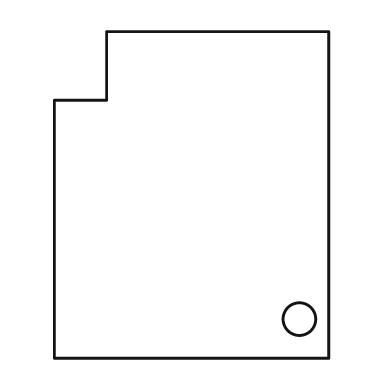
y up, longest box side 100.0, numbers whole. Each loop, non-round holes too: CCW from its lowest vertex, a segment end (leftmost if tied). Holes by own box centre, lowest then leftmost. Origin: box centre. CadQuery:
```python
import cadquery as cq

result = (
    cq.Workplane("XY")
    .moveTo(-42.0, -50.0)
    .lineTo(42.0, -50.0)
    .lineTo(42.0, 50.0)
    .lineTo(-26.0, 50.0)
    .lineTo(-26.0, 29.0)
    .lineTo(-42.0, 29.0)
    .close()
    .moveTo(33.0, -38.0)
    .circle(5.0)
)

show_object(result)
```